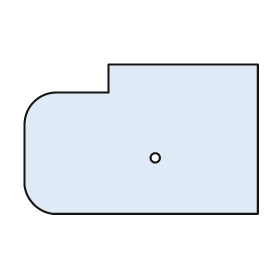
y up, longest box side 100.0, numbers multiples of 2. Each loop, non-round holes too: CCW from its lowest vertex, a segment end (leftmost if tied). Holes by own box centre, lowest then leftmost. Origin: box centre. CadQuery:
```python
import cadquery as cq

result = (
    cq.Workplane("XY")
    .moveTo(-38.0, -32.0)
    .lineTo(50.0, -32.0)
    .lineTo(50.0, 32.0)
    .lineTo(-14.0, 32.0)
    .lineTo(-14.0, 20.0)
    .lineTo(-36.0, 20.0)
    .threePointArc((-46.0, 16.0), (-50.0, 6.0))
    .lineTo(-50.0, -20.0)
    .threePointArc((-46.0, -28.0), (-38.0, -32.0))
    .close()
    .moveTo(6.0, -8.0)
    .circle(2.0)
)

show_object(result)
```